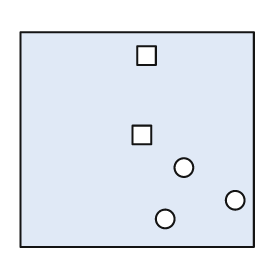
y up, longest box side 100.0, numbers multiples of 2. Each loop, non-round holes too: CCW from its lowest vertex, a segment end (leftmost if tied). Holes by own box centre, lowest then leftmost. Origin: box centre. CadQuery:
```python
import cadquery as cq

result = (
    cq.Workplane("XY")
    .moveTo(-50.0, -46.0)
    .lineTo(50.0, -46.0)
    .lineTo(50.0, 46.0)
    .lineTo(-50.0, 46.0)
    .close()
    .moveTo(12.0, -34.0)
    .circle(4.0)
    .moveTo(42.0, -26.0)
    .circle(4.0)
    .moveTo(20.0, -12.0)
    .circle(4.0)
    .moveTo(-2.0, -2.0)
    .lineTo(6.0, -2.0)
    .lineTo(6.0, 6.0)
    .lineTo(-2.0, 6.0)
    .close()
    .moveTo(0.0, 32.0)
    .lineTo(8.0, 32.0)
    .lineTo(8.0, 40.0)
    .lineTo(0.0, 40.0)
    .close()
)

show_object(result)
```